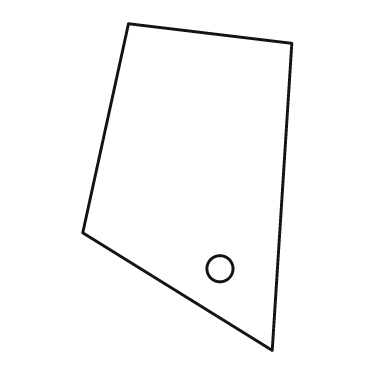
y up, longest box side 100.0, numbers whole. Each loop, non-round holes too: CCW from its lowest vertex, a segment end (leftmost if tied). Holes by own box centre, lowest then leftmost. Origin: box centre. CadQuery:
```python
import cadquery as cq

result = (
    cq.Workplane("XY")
    .moveTo(26.0, -50.0)
    .lineTo(32.0, 44.0)
    .lineTo(-18.0, 50.0)
    .lineTo(-32.0, -14.0)
    .close()
    .moveTo(10.0, -25.0)
    .circle(4.0)
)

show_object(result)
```